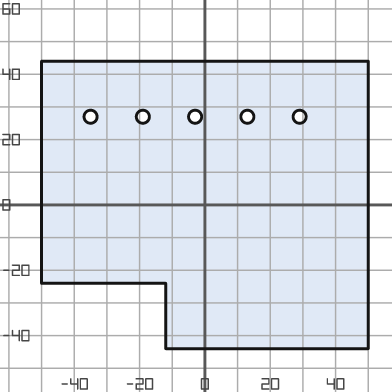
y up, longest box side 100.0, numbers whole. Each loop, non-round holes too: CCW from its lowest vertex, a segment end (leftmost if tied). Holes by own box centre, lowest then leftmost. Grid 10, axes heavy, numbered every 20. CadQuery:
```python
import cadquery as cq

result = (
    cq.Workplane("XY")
    .moveTo(-12.0, -44.0)
    .lineTo(50.0, -44.0)
    .lineTo(50.0, 44.0)
    .lineTo(-50.0, 44.0)
    .lineTo(-50.0, -24.0)
    .lineTo(-12.0, -24.0)
    .close()
    .moveTo(-35.0, 27.0)
    .circle(2.0)
    .moveTo(-19.0, 27.0)
    .circle(2.0)
    .moveTo(-3.0, 27.0)
    .circle(2.0)
    .moveTo(13.0, 27.0)
    .circle(2.0)
    .moveTo(29.0, 27.0)
    .circle(2.0)
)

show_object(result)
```